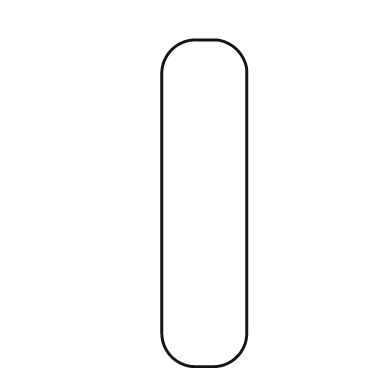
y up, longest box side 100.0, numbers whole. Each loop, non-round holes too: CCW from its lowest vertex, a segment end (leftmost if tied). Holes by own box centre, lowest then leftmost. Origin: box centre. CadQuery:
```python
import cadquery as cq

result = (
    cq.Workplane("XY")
    .moveTo(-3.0, -50.0)
    .lineTo(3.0, -50.0)
    .threePointArc((10.0, -47.0), (13.0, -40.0))
    .lineTo(13.0, 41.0)
    .threePointArc((10.0, 47.0), (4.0, 50.0))
    .lineTo(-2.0, 50.0)
    .threePointArc((-10.0, 47.0), (-13.0, 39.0))
    .lineTo(-13.0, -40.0)
    .threePointArc((-10.0, -47.0), (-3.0, -50.0))
    .close()
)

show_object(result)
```